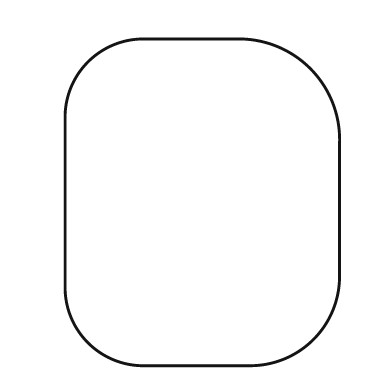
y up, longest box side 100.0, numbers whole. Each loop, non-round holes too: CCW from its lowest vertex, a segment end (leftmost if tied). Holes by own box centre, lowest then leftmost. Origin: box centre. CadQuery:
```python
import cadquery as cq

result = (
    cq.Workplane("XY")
    .moveTo(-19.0, -50.0)
    .lineTo(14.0, -50.0)
    .threePointArc((34.0, -42.0), (42.0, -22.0))
    .lineTo(42.0, 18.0)
    .threePointArc((33.0, 41.0), (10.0, 50.0))
    .lineTo(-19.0, 50.0)
    .threePointArc((-35.0, 43.0), (-42.0, 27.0))
    .lineTo(-42.0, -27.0)
    .threePointArc((-35.0, -43.0), (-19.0, -50.0))
    .close()
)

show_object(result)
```